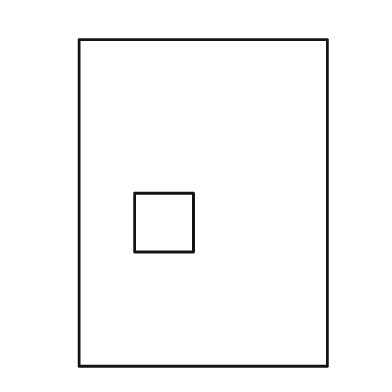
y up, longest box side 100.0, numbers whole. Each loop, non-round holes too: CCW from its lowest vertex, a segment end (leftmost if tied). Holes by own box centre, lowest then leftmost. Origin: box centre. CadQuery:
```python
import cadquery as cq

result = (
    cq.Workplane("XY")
    .moveTo(-38.0, -50.0)
    .lineTo(38.0, -50.0)
    .lineTo(38.0, 50.0)
    .lineTo(-38.0, 50.0)
    .close()
    .moveTo(-21.0, -15.0)
    .lineTo(-3.0, -15.0)
    .lineTo(-3.0, 3.0)
    .lineTo(-21.0, 3.0)
    .close()
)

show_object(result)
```